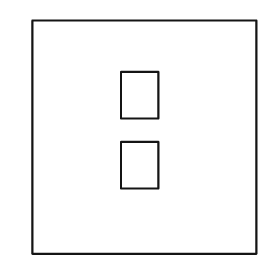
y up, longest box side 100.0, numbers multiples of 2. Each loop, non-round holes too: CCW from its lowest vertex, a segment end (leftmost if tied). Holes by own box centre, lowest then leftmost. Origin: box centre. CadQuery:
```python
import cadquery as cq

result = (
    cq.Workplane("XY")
    .moveTo(-48.0, -50.0)
    .lineTo(48.0, -50.0)
    .lineTo(48.0, 50.0)
    .lineTo(-48.0, 50.0)
    .close()
    .moveTo(-10.0, -22.0)
    .lineTo(6.0, -22.0)
    .lineTo(6.0, -2.0)
    .lineTo(-10.0, -2.0)
    .close()
    .moveTo(-10.0, 8.0)
    .lineTo(6.0, 8.0)
    .lineTo(6.0, 28.0)
    .lineTo(-10.0, 28.0)
    .close()
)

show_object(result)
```